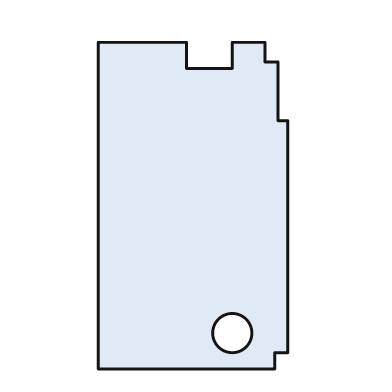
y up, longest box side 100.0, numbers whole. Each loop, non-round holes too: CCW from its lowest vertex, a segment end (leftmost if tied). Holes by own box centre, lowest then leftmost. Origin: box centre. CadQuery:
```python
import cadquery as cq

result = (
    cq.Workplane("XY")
    .moveTo(-29.0, -50.0)
    .lineTo(25.0, -50.0)
    .lineTo(25.0, -45.0)
    .lineTo(29.0, -45.0)
    .lineTo(29.0, 26.0)
    .lineTo(26.0, 26.0)
    .lineTo(26.0, 44.0)
    .lineTo(22.0, 44.0)
    .lineTo(22.0, 50.0)
    .lineTo(12.0, 50.0)
    .lineTo(12.0, 42.0)
    .lineTo(-2.0, 42.0)
    .lineTo(-2.0, 50.0)
    .lineTo(-29.0, 50.0)
    .close()
    .moveTo(12.0, -39.0)
    .circle(6.0)
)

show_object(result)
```